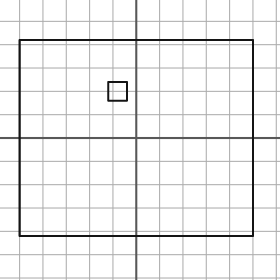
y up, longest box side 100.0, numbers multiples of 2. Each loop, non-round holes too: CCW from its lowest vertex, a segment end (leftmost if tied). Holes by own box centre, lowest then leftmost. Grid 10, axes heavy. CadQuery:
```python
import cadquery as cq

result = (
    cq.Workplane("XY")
    .moveTo(-50.0, -42.0)
    .lineTo(50.0, -42.0)
    .lineTo(50.0, 42.0)
    .lineTo(-50.0, 42.0)
    .close()
    .moveTo(-12.0, 16.0)
    .lineTo(-4.0, 16.0)
    .lineTo(-4.0, 24.0)
    .lineTo(-12.0, 24.0)
    .close()
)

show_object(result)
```